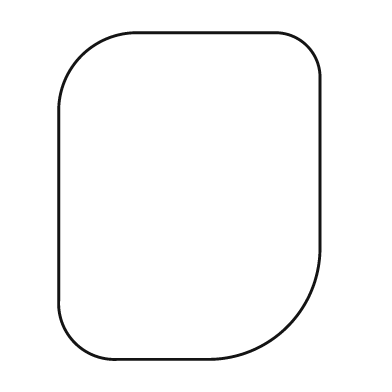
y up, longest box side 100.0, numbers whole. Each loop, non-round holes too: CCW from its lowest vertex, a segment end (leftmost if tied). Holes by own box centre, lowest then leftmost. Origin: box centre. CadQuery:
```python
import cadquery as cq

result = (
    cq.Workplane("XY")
    .moveTo(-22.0, -50.0)
    .lineTo(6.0, -50.0)
    .threePointArc((30.0, -40.0), (40.0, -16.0))
    .lineTo(40.0, 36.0)
    .threePointArc((36.0, 46.0), (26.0, 50.0))
    .lineTo(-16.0, 50.0)
    .threePointArc((-33.0, 43.0), (-40.0, 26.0))
    .lineTo(-40.0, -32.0)
    .threePointArc((-35.0, -45.0), (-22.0, -50.0))
    .close()
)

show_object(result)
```